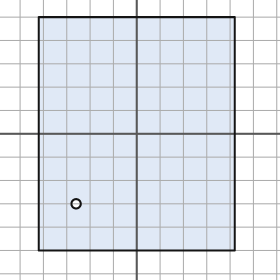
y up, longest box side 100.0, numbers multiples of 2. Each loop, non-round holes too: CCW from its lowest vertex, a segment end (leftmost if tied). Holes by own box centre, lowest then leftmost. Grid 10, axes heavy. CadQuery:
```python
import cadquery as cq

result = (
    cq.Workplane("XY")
    .moveTo(-42.0, -50.0)
    .lineTo(42.0, -50.0)
    .lineTo(42.0, 50.0)
    .lineTo(-42.0, 50.0)
    .close()
    .moveTo(-26.0, -30.0)
    .circle(2.0)
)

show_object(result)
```